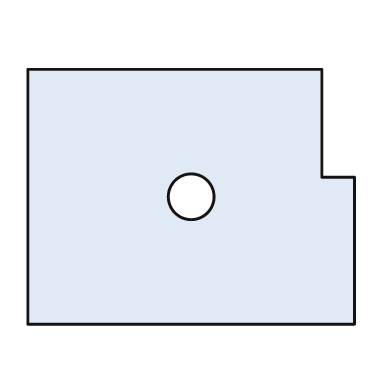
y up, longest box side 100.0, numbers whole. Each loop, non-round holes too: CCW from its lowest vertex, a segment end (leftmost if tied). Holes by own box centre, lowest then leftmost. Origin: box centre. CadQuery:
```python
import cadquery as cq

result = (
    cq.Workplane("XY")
    .moveTo(-50.0, -39.0)
    .lineTo(50.0, -39.0)
    .lineTo(50.0, 6.0)
    .lineTo(40.0, 6.0)
    .lineTo(40.0, 39.0)
    .lineTo(-50.0, 39.0)
    .close()
    .moveTo(0.0, 0.0)
    .circle(7.0)
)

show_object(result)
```